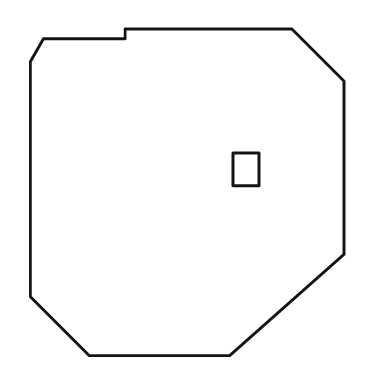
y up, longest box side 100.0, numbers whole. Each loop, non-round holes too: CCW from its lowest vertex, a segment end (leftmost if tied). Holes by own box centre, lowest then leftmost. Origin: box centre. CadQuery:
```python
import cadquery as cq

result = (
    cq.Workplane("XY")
    .moveTo(-30.0, -50.0)
    .lineTo(13.0, -50.0)
    .lineTo(48.0, -19.0)
    .lineTo(48.0, 34.0)
    .lineTo(32.0, 50.0)
    .lineTo(-19.0, 50.0)
    .lineTo(-19.0, 47.0)
    .lineTo(-44.0, 47.0)
    .lineTo(-48.0, 40.0)
    .lineTo(-48.0, -32.0)
    .close()
    .moveTo(14.0, 2.0)
    .lineTo(22.0, 2.0)
    .lineTo(22.0, 12.0)
    .lineTo(14.0, 12.0)
    .close()
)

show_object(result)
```